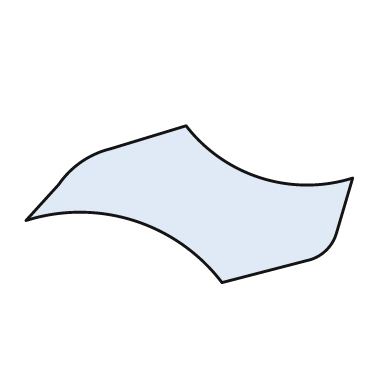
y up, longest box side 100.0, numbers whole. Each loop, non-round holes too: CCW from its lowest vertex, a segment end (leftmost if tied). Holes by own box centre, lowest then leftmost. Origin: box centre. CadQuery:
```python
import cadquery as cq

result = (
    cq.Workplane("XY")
    .moveTo(10.0, -24.0)
    .lineTo(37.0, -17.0)
    .threePointArc((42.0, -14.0), (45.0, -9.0))
    .lineTo(50.0, 8.0)
    .threePointArc((22.0, 8.0), (-1.0, 24.0))
    .lineTo(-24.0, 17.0)
    .threePointArc((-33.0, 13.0), (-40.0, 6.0))
    .lineTo(-50.0, -5.0)
    .threePointArc((-17.0, -5.0), (10.0, -24.0))
    .close()
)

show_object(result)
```